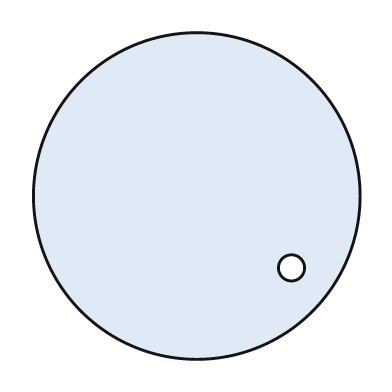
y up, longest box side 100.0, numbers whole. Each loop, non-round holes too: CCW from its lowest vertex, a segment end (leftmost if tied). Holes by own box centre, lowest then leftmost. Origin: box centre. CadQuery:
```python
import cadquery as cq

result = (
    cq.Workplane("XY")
    .moveTo(0.0, 0.0)
    .circle(50.0)
    .moveTo(29.0, -22.0)
    .circle(4.0)
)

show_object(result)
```